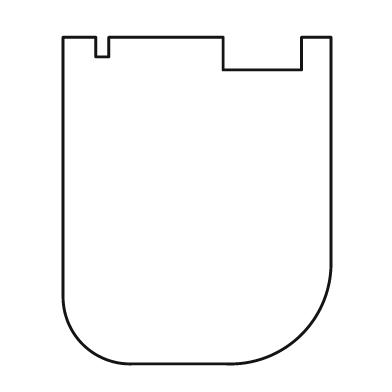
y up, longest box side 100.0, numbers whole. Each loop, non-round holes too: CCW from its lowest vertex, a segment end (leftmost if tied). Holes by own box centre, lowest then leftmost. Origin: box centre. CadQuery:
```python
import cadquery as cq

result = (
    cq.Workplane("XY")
    .moveTo(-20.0, -50.0)
    .lineTo(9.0, -50.0)
    .threePointArc((32.0, -41.0), (41.0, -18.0))
    .lineTo(41.0, 50.0)
    .lineTo(32.0, 50.0)
    .lineTo(32.0, 40.0)
    .lineTo(8.0, 40.0)
    .lineTo(8.0, 50.0)
    .lineTo(-27.0, 50.0)
    .lineTo(-27.0, 44.0)
    .lineTo(-31.0, 44.0)
    .lineTo(-31.0, 50.0)
    .lineTo(-41.0, 50.0)
    .lineTo(-41.0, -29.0)
    .threePointArc((-35.0, -44.0), (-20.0, -50.0))
    .close()
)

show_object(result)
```